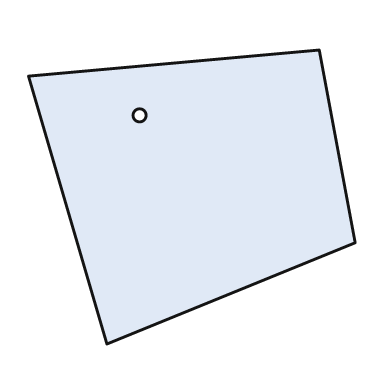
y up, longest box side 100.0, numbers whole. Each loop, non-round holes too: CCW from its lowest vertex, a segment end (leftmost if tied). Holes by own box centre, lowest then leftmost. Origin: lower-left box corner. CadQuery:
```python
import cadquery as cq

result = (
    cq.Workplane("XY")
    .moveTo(24.0, 0.0)
    .lineTo(100.0, 31.0)
    .lineTo(89.0, 90.0)
    .lineTo(0.0, 82.0)
    .close()
    .moveTo(34.0, 70.0)
    .circle(2.0)
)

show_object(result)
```